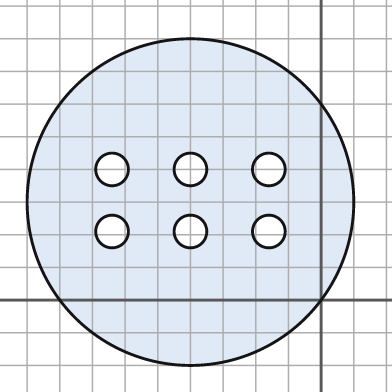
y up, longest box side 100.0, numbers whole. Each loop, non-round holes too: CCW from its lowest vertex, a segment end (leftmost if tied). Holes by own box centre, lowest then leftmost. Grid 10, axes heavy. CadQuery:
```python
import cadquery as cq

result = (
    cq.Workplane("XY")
    .moveTo(-40.0, 30.0)
    .circle(50.0)
    .moveTo(-64.0, 21.0)
    .circle(5.0)
    .moveTo(-40.0, 21.0)
    .circle(5.0)
    .moveTo(-16.0, 21.0)
    .circle(5.0)
    .moveTo(-64.0, 40.0)
    .circle(5.0)
    .moveTo(-40.0, 40.0)
    .circle(5.0)
    .moveTo(-16.0, 40.0)
    .circle(5.0)
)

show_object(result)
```